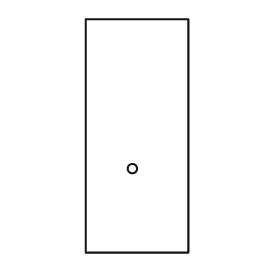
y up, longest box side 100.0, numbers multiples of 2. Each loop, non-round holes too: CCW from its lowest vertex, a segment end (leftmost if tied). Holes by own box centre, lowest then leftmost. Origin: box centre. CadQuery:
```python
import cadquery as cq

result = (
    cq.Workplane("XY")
    .moveTo(-22.0, -50.0)
    .lineTo(22.0, -50.0)
    .lineTo(22.0, 50.0)
    .lineTo(-22.0, 50.0)
    .close()
    .moveTo(-2.0, -14.0)
    .circle(2.0)
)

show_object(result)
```